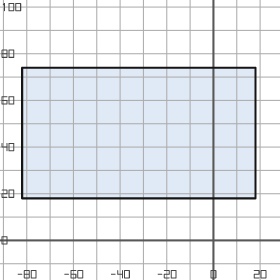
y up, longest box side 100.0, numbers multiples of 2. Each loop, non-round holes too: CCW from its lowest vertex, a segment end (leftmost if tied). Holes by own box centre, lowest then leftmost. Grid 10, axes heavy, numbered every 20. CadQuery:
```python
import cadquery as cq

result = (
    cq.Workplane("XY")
    .moveTo(-82.0, 18.0)
    .lineTo(18.0, 18.0)
    .lineTo(18.0, 74.0)
    .lineTo(-82.0, 74.0)
    .close()
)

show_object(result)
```